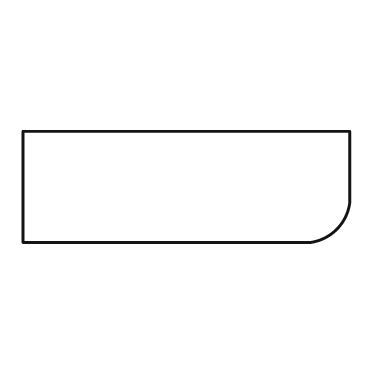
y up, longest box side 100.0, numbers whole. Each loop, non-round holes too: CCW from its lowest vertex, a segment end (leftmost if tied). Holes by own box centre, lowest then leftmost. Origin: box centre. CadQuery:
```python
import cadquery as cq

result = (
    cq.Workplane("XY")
    .moveTo(-50.0, -17.0)
    .lineTo(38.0, -17.0)
    .threePointArc((46.0, -13.0), (50.0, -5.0))
    .lineTo(50.0, 17.0)
    .lineTo(-50.0, 17.0)
    .close()
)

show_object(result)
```